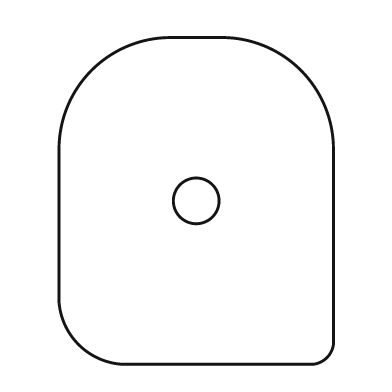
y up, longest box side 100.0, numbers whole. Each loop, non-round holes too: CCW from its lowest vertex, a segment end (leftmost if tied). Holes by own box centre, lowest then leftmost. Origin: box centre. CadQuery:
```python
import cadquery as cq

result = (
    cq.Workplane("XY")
    .moveTo(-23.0, -50.0)
    .lineTo(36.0, -50.0)
    .threePointArc((40.0, -48.0), (42.0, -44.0))
    .lineTo(42.0, 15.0)
    .threePointArc((32.0, 40.0), (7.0, 50.0))
    .lineTo(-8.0, 50.0)
    .threePointArc((-32.0, 40.0), (-42.0, 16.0))
    .lineTo(-42.0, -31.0)
    .threePointArc((-36.0, -44.0), (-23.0, -50.0))
    .close()
    .moveTo(0.0, 0.0)
    .circle(7.0)
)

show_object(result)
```